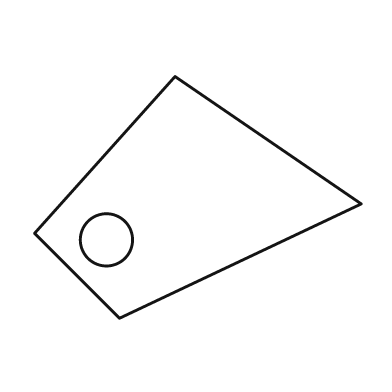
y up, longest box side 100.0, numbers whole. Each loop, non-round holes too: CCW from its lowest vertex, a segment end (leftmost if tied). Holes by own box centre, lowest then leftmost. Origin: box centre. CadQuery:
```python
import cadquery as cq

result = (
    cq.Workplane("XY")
    .moveTo(-24.0, -37.0)
    .lineTo(50.0, -2.0)
    .lineTo(-7.0, 37.0)
    .lineTo(-50.0, -11.0)
    .close()
    .moveTo(-28.0, -13.0)
    .circle(8.0)
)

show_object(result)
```